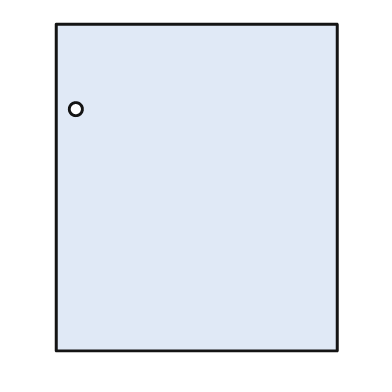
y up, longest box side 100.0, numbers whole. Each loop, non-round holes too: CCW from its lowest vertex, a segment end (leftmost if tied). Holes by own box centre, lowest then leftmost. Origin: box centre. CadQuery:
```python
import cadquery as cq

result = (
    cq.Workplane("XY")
    .moveTo(-43.0, -50.0)
    .lineTo(43.0, -50.0)
    .lineTo(43.0, 50.0)
    .lineTo(-43.0, 50.0)
    .close()
    .moveTo(-37.0, 24.0)
    .circle(2.0)
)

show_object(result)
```